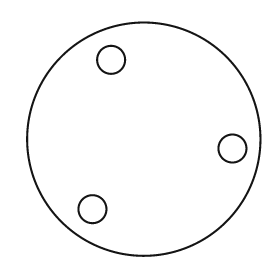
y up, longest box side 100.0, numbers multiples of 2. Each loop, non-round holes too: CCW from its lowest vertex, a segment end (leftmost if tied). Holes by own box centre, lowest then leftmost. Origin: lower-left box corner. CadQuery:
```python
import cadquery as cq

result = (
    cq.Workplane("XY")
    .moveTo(50.0, 50.0)
    .circle(50.0)
    .moveTo(28.0, 20.0)
    .circle(6.0)
    .moveTo(88.0, 46.0)
    .circle(6.0)
    .moveTo(36.0, 84.0)
    .circle(6.0)
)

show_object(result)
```